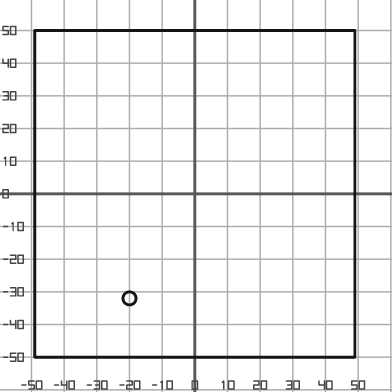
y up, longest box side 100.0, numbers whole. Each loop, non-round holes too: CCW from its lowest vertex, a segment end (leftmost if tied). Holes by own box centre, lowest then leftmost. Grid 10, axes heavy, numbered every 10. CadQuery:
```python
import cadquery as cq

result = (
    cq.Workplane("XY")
    .moveTo(-49.0, -50.0)
    .lineTo(49.0, -50.0)
    .lineTo(49.0, 50.0)
    .lineTo(-49.0, 50.0)
    .close()
    .moveTo(-20.0, -32.0)
    .circle(2.0)
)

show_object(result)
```